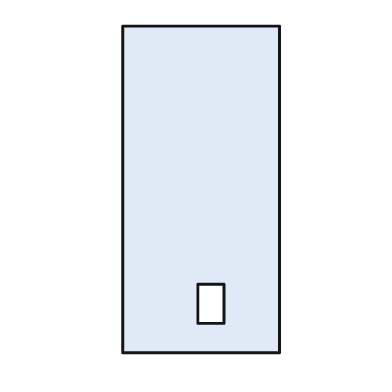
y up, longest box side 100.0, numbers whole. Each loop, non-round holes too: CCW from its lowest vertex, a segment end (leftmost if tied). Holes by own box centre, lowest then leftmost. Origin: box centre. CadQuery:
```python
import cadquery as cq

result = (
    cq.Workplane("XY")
    .moveTo(-24.0, -50.0)
    .lineTo(24.0, -50.0)
    .lineTo(24.0, 50.0)
    .lineTo(-24.0, 50.0)
    .close()
    .moveTo(-1.0, -41.0)
    .lineTo(7.0, -41.0)
    .lineTo(7.0, -29.0)
    .lineTo(-1.0, -29.0)
    .close()
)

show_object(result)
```